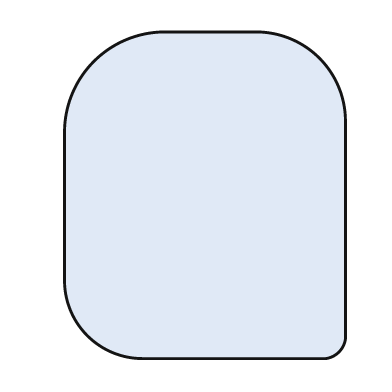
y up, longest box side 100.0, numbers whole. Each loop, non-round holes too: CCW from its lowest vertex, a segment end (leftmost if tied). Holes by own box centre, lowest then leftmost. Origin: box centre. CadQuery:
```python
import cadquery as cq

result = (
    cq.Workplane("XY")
    .moveTo(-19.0, -50.0)
    .lineTo(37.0, -50.0)
    .threePointArc((41.0, -48.0), (43.0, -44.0))
    .lineTo(43.0, 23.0)
    .threePointArc((35.0, 42.0), (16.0, 50.0))
    .lineTo(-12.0, 50.0)
    .threePointArc((-34.0, 41.0), (-43.0, 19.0))
    .lineTo(-43.0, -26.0)
    .threePointArc((-36.0, -43.0), (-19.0, -50.0))
    .close()
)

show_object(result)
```